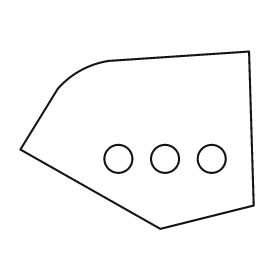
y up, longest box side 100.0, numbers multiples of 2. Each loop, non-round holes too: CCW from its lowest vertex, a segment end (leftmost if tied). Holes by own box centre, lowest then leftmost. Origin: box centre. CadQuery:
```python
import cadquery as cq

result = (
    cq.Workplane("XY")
    .moveTo(10.0, -38.0)
    .lineTo(50.0, -28.0)
    .lineTo(48.0, 38.0)
    .lineTo(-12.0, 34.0)
    .threePointArc((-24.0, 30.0), (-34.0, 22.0))
    .lineTo(-50.0, -4.0)
    .close()
    .moveTo(-8.0, -8.0)
    .circle(6.0)
    .moveTo(12.0, -8.0)
    .circle(6.0)
    .moveTo(32.0, -8.0)
    .circle(6.0)
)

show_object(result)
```